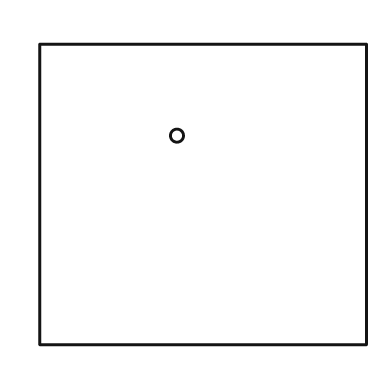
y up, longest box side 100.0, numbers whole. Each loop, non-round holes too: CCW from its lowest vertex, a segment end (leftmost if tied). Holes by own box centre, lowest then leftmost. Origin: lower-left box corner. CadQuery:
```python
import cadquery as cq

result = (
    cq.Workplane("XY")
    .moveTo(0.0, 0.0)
    .lineTo(100.0, 0.0)
    .lineTo(100.0, 92.0)
    .lineTo(0.0, 92.0)
    .close()
    .moveTo(42.0, 64.0)
    .circle(2.0)
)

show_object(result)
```